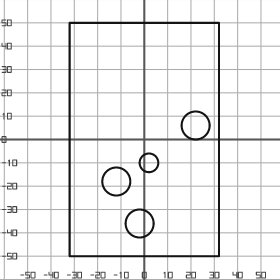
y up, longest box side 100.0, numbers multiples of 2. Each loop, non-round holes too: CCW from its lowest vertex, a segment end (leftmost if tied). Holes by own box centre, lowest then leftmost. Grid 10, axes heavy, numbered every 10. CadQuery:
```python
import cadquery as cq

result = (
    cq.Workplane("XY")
    .moveTo(-32.0, -50.0)
    .lineTo(32.0, -50.0)
    .lineTo(32.0, 50.0)
    .lineTo(-32.0, 50.0)
    .close()
    .moveTo(-2.0, -36.0)
    .circle(6.0)
    .moveTo(-12.0, -18.0)
    .circle(6.0)
    .moveTo(2.0, -10.0)
    .circle(4.0)
    .moveTo(22.0, 6.0)
    .circle(6.0)
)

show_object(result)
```